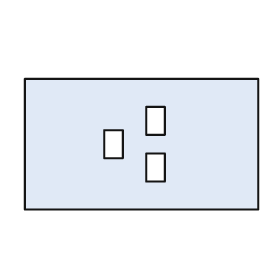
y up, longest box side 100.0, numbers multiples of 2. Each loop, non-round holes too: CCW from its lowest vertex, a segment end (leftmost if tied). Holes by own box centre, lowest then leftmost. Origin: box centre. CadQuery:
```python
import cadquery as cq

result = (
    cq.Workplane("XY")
    .moveTo(-50.0, -28.0)
    .lineTo(50.0, -28.0)
    .lineTo(50.0, 28.0)
    .lineTo(-50.0, 28.0)
    .close()
    .moveTo(2.0, -16.0)
    .lineTo(10.0, -16.0)
    .lineTo(10.0, -4.0)
    .lineTo(2.0, -4.0)
    .close()
    .moveTo(-16.0, -6.0)
    .lineTo(-8.0, -6.0)
    .lineTo(-8.0, 6.0)
    .lineTo(-16.0, 6.0)
    .close()
    .moveTo(2.0, 4.0)
    .lineTo(10.0, 4.0)
    .lineTo(10.0, 16.0)
    .lineTo(2.0, 16.0)
    .close()
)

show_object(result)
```